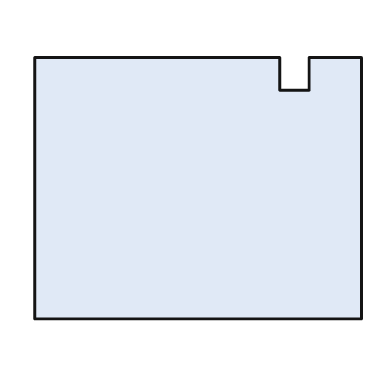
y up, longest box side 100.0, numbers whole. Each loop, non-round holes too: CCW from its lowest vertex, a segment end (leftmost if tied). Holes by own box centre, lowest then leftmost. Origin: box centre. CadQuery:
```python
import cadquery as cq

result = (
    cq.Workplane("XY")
    .moveTo(-50.0, -40.0)
    .lineTo(50.0, -40.0)
    .lineTo(50.0, 40.0)
    .lineTo(34.0, 40.0)
    .lineTo(34.0, 30.0)
    .lineTo(25.0, 30.0)
    .lineTo(25.0, 40.0)
    .lineTo(-50.0, 40.0)
    .close()
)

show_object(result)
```